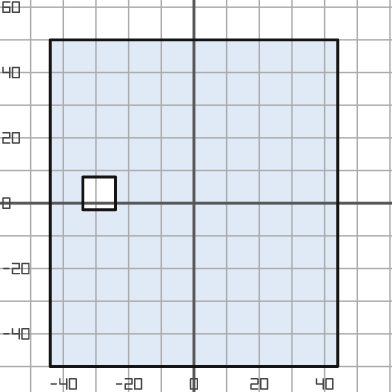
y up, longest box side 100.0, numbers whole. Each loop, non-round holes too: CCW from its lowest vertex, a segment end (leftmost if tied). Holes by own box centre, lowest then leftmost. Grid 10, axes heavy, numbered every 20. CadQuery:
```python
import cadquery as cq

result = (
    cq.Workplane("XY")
    .moveTo(-44.0, -50.0)
    .lineTo(44.0, -50.0)
    .lineTo(44.0, 50.0)
    .lineTo(-44.0, 50.0)
    .close()
    .moveTo(-34.0, -2.0)
    .lineTo(-24.0, -2.0)
    .lineTo(-24.0, 8.0)
    .lineTo(-34.0, 8.0)
    .close()
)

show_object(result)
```